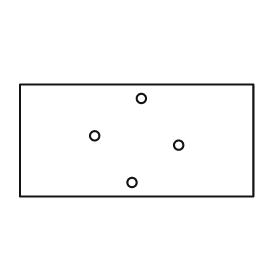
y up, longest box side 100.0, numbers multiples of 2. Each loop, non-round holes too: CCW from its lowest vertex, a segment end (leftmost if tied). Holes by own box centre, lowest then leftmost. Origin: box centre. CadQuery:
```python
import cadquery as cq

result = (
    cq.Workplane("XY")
    .moveTo(-50.0, -24.0)
    .lineTo(50.0, -24.0)
    .lineTo(50.0, 24.0)
    .lineTo(-50.0, 24.0)
    .close()
    .moveTo(-2.0, -18.0)
    .circle(2.0)
    .moveTo(18.0, -2.0)
    .circle(2.0)
    .moveTo(-18.0, 2.0)
    .circle(2.0)
    .moveTo(2.0, 18.0)
    .circle(2.0)
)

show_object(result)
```